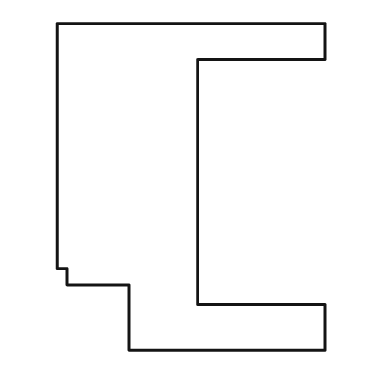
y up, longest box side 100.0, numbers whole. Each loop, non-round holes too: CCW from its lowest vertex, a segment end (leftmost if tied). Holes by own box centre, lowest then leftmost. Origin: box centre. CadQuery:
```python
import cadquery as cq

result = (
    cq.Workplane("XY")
    .moveTo(-19.0, -50.0)
    .lineTo(41.0, -50.0)
    .lineTo(41.0, -36.0)
    .lineTo(2.0, -36.0)
    .lineTo(2.0, 39.0)
    .lineTo(41.0, 39.0)
    .lineTo(41.0, 50.0)
    .lineTo(-41.0, 50.0)
    .lineTo(-41.0, -25.0)
    .lineTo(-38.0, -25.0)
    .lineTo(-38.0, -30.0)
    .lineTo(-19.0, -30.0)
    .close()
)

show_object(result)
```